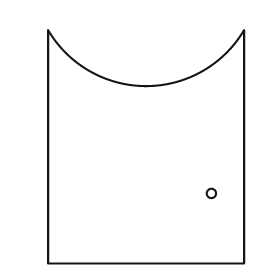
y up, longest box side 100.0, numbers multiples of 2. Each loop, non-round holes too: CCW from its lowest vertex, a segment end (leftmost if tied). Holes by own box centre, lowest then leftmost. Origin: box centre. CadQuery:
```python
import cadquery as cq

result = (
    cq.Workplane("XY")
    .moveTo(-42.0, -50.0)
    .lineTo(42.0, -50.0)
    .lineTo(42.0, 50.0)
    .threePointArc((0.0, 26.0), (-42.0, 50.0))
    .close()
    .moveTo(28.0, -20.0)
    .circle(2.0)
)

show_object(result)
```